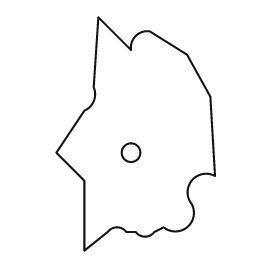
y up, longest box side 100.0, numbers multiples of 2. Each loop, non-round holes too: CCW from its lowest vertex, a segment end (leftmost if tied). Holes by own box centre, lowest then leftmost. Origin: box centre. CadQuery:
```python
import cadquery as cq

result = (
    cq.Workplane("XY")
    .moveTo(-22.0, -50.0)
    .lineTo(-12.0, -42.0)
    .threePointArc((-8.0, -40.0), (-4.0, -42.0))
    .lineTo(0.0, -42.0)
    .threePointArc((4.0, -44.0), (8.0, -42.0))
    .lineTo(12.0, -40.0)
    .threePointArc((22.0, -40.0), (24.0, -30.0))
    .threePointArc((24.0, -20.0), (34.0, -18.0))
    .lineTo(32.0, 16.0)
    .lineTo(22.0, 34.0)
    .lineTo(6.0, 44.0)
    .threePointArc((0.0, 42.0), (-2.0, 36.0))
    .lineTo(-16.0, 50.0)
    .lineTo(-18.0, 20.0)
    .threePointArc((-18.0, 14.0), (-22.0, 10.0))
    .lineTo(-34.0, -8.0)
    .lineTo(-22.0, -20.0)
    .close()
    .moveTo(-2.0, -8.0)
    .circle(4.0)
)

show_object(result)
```